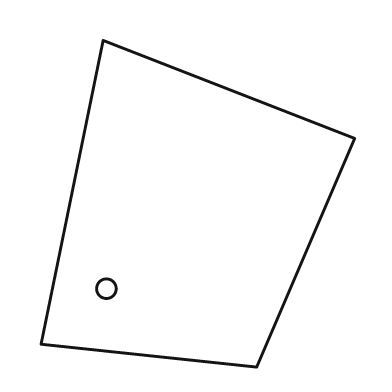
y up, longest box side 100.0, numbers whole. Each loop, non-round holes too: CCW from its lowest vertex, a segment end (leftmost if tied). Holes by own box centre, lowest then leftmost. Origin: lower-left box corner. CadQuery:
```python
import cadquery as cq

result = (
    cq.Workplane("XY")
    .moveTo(66.0, 0.0)
    .lineTo(96.0, 70.0)
    .lineTo(19.0, 100.0)
    .lineTo(0.0, 7.0)
    .close()
    .moveTo(20.0, 24.0)
    .circle(3.0)
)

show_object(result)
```